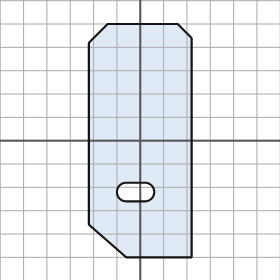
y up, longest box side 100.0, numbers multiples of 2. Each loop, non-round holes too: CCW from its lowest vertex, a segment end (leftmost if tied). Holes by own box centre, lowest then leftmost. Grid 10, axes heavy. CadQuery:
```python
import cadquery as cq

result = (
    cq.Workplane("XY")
    .moveTo(-6.0, -50.0)
    .lineTo(22.0, -50.0)
    .lineTo(22.0, 44.0)
    .lineTo(16.0, 50.0)
    .lineTo(-14.0, 50.0)
    .lineTo(-22.0, 42.0)
    .lineTo(-22.0, -36.0)
    .close()
    .moveTo(-6.0, -26.0)
    .lineTo(2.0, -26.0)
    .threePointArc((6.0, -22.0), (2.0, -18.0))
    .lineTo(-6.0, -18.0)
    .threePointArc((-10.0, -22.0), (-6.0, -26.0))
    .close()
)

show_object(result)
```